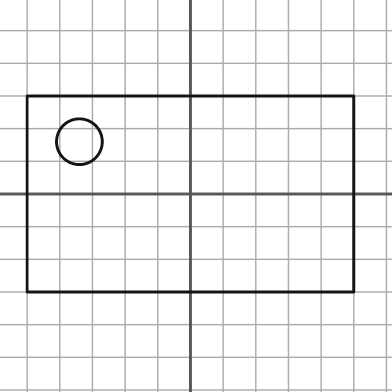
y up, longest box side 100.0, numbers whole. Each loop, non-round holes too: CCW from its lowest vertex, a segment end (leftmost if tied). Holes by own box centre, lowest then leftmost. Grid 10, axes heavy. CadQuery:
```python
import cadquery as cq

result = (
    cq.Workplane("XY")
    .moveTo(-50.0, -30.0)
    .lineTo(50.0, -30.0)
    .lineTo(50.0, 30.0)
    .lineTo(-50.0, 30.0)
    .close()
    .moveTo(-34.0, 16.0)
    .circle(7.0)
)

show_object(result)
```